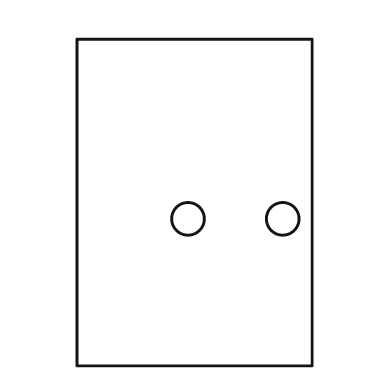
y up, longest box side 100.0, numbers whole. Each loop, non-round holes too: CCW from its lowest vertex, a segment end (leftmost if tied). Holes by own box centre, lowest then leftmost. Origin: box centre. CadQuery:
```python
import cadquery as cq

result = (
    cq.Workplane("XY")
    .moveTo(-36.0, -50.0)
    .lineTo(36.0, -50.0)
    .lineTo(36.0, 50.0)
    .lineTo(-36.0, 50.0)
    .close()
    .moveTo(-2.0, -5.0)
    .circle(5.0)
    .moveTo(27.0, -5.0)
    .circle(5.0)
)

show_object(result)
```